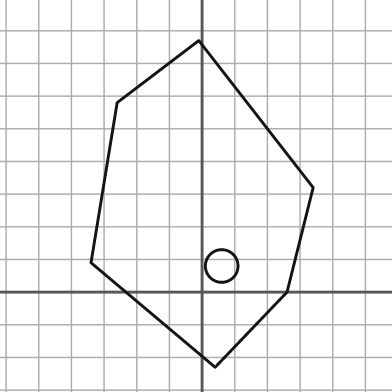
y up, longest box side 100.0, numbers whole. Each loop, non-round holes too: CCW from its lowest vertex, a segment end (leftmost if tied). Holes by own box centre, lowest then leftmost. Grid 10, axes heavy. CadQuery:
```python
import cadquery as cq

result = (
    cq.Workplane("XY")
    .moveTo(4.0, -23.0)
    .lineTo(26.0, 0.0)
    .lineTo(34.0, 32.0)
    .lineTo(-1.0, 77.0)
    .lineTo(-26.0, 58.0)
    .lineTo(-34.0, 9.0)
    .close()
    .moveTo(6.0, 8.0)
    .circle(5.0)
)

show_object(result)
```